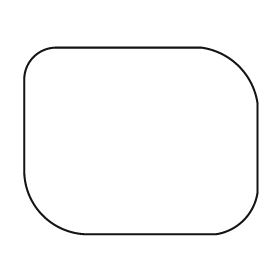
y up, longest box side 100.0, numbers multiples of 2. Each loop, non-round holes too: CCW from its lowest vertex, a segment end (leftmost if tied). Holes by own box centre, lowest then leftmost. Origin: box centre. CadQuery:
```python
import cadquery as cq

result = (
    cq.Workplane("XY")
    .moveTo(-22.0, -40.0)
    .lineTo(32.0, -40.0)
    .threePointArc((44.0, -34.0), (50.0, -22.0))
    .lineTo(50.0, 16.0)
    .threePointArc((42.0, 32.0), (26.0, 40.0))
    .lineTo(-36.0, 40.0)
    .threePointArc((-46.0, 36.0), (-50.0, 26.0))
    .lineTo(-50.0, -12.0)
    .threePointArc((-42.0, -32.0), (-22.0, -40.0))
    .close()
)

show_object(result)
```